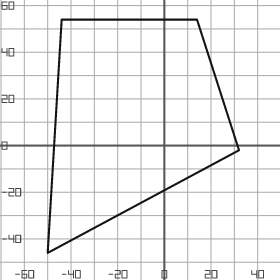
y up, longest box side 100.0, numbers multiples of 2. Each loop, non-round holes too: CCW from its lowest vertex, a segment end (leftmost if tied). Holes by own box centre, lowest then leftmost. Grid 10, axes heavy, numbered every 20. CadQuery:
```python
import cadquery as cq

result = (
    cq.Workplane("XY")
    .moveTo(-50.0, -46.0)
    .lineTo(32.0, -2.0)
    .lineTo(14.0, 54.0)
    .lineTo(-44.0, 54.0)
    .close()
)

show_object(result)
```